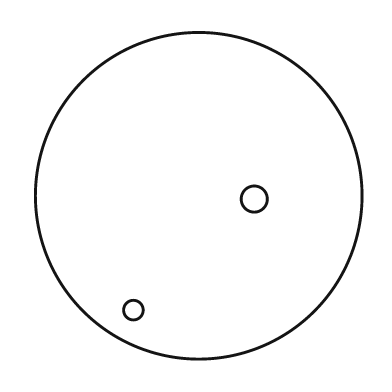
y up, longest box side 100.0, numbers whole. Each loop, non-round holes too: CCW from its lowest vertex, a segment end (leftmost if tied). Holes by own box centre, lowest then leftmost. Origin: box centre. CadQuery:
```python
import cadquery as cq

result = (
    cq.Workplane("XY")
    .moveTo(0.0, 0.0)
    .circle(50.0)
    .moveTo(-20.0, -35.0)
    .circle(3.0)
    .moveTo(17.0, -1.0)
    .circle(4.0)
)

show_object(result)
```